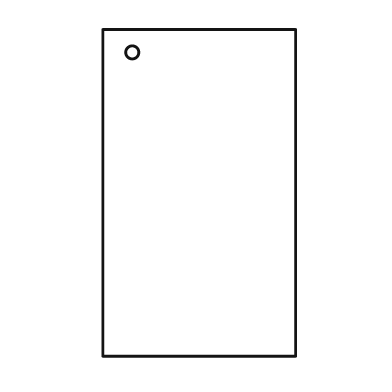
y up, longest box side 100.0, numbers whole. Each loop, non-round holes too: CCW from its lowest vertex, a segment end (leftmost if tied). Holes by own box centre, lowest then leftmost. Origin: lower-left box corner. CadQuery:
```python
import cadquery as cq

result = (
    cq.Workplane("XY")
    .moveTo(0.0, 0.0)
    .lineTo(59.0, 0.0)
    .lineTo(59.0, 100.0)
    .lineTo(0.0, 100.0)
    .close()
    .moveTo(9.0, 93.0)
    .circle(2.0)
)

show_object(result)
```